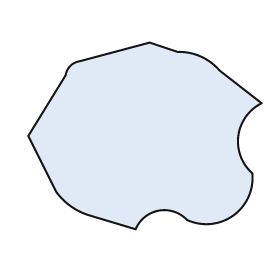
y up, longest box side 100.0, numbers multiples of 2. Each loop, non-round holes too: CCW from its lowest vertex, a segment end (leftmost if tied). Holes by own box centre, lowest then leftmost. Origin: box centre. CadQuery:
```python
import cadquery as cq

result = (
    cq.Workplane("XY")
    .moveTo(-4.0, -40.0)
    .threePointArc((6.0, -32.0), (18.0, -36.0))
    .threePointArc((38.0, -34.0), (46.0, -16.0))
    .threePointArc((40.0, 0.0), (50.0, 14.0))
    .lineTo(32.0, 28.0)
    .threePointArc((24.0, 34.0), (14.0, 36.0))
    .lineTo(2.0, 40.0)
    .lineTo(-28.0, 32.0)
    .threePointArc((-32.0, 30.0), (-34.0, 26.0))
    .lineTo(-50.0, 0.0)
    .lineTo(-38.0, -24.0)
    .threePointArc((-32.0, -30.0), (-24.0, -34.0))
    .close()
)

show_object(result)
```